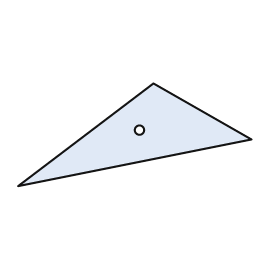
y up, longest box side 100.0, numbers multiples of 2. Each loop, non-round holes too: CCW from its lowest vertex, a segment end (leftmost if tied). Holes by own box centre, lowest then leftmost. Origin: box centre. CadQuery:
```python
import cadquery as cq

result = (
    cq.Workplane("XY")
    .moveTo(-50.0, -22.0)
    .lineTo(50.0, -2.0)
    .lineTo(8.0, 22.0)
    .close()
    .moveTo(2.0, 2.0)
    .circle(2.0)
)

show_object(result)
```